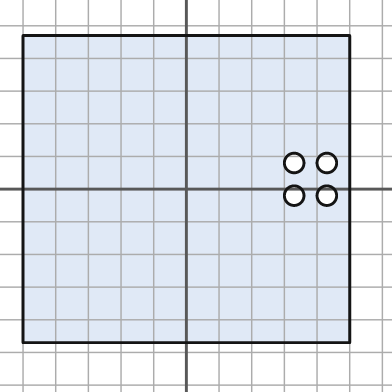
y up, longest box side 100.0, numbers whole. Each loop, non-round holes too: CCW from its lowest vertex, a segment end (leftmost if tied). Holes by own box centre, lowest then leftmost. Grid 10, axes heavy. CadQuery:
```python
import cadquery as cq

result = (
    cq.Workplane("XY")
    .moveTo(-50.0, -47.0)
    .lineTo(50.0, -47.0)
    .lineTo(50.0, 47.0)
    .lineTo(-50.0, 47.0)
    .close()
    .moveTo(33.0, -2.0)
    .circle(3.0)
    .moveTo(43.0, -2.0)
    .circle(3.0)
    .moveTo(33.0, 8.0)
    .circle(3.0)
    .moveTo(43.0, 8.0)
    .circle(3.0)
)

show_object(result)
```